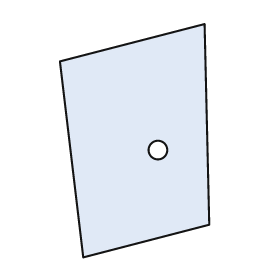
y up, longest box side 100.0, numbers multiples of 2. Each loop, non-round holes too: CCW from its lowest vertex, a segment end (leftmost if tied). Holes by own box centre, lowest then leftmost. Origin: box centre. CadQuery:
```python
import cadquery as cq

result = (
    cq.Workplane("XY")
    .moveTo(-22.0, -50.0)
    .lineTo(32.0, -36.0)
    .lineTo(30.0, 50.0)
    .lineTo(-32.0, 34.0)
    .close()
    .moveTo(10.0, -4.0)
    .circle(4.0)
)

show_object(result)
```